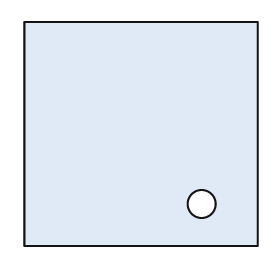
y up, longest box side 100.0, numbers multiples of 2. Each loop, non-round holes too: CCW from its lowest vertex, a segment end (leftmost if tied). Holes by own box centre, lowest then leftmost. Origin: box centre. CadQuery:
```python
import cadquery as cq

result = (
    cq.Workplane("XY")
    .moveTo(-50.0, -48.0)
    .lineTo(50.0, -48.0)
    .lineTo(50.0, 48.0)
    .lineTo(-50.0, 48.0)
    .close()
    .moveTo(26.0, -30.0)
    .circle(6.0)
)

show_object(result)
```